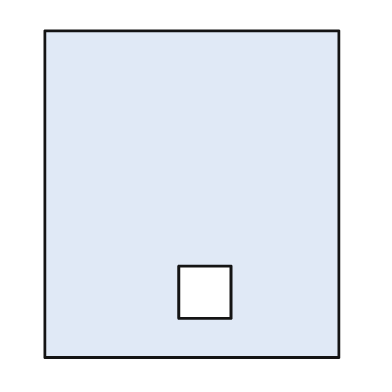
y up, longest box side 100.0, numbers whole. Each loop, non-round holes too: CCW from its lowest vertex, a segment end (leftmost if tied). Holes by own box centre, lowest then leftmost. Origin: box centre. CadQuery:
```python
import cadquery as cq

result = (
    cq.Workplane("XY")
    .moveTo(-45.0, -50.0)
    .lineTo(45.0, -50.0)
    .lineTo(45.0, 50.0)
    .lineTo(-45.0, 50.0)
    .close()
    .moveTo(-4.0, -38.0)
    .lineTo(12.0, -38.0)
    .lineTo(12.0, -22.0)
    .lineTo(-4.0, -22.0)
    .close()
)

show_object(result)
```